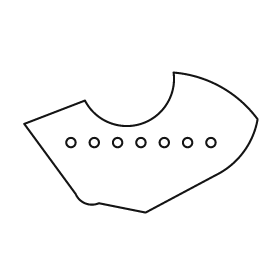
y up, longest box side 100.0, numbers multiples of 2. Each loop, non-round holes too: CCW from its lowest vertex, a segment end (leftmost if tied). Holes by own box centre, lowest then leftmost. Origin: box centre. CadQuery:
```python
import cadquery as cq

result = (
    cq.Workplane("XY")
    .moveTo(2.0, -30.0)
    .lineTo(32.0, -14.0)
    .threePointArc((44.0, -4.0), (50.0, 10.0))
    .threePointArc((34.0, 24.0), (14.0, 30.0))
    .threePointArc((0.0, 8.0), (-24.0, 18.0))
    .lineTo(-50.0, 8.0)
    .lineTo(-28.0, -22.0)
    .threePointArc((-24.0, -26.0), (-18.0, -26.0))
    .close()
    .moveTo(-30.0, 0.0)
    .circle(2.0)
    .moveTo(-20.0, 0.0)
    .circle(2.0)
    .moveTo(-10.0, 0.0)
    .circle(2.0)
    .moveTo(0.0, 0.0)
    .circle(2.0)
    .moveTo(10.0, 0.0)
    .circle(2.0)
    .moveTo(20.0, 0.0)
    .circle(2.0)
    .moveTo(30.0, 0.0)
    .circle(2.0)
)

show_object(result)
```